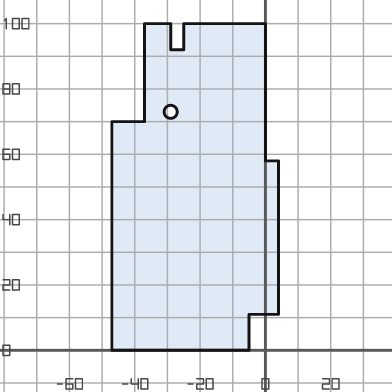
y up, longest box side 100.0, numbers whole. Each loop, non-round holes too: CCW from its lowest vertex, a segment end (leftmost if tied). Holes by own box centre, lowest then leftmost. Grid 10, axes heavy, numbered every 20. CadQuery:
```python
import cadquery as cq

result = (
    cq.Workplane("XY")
    .moveTo(-47.0, 0.0)
    .lineTo(-5.0, 0.0)
    .lineTo(-5.0, 11.0)
    .lineTo(4.0, 11.0)
    .lineTo(4.0, 58.0)
    .lineTo(0.0, 58.0)
    .lineTo(0.0, 100.0)
    .lineTo(-25.0, 100.0)
    .lineTo(-25.0, 92.0)
    .lineTo(-29.0, 92.0)
    .lineTo(-29.0, 100.0)
    .lineTo(-37.0, 100.0)
    .lineTo(-37.0, 70.0)
    .lineTo(-47.0, 70.0)
    .close()
    .moveTo(-29.0, 73.0)
    .circle(2.0)
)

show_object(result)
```